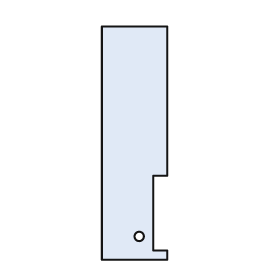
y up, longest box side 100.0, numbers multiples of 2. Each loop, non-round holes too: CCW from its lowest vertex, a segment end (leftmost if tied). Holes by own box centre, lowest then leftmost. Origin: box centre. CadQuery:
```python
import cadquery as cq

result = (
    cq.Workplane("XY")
    .moveTo(-14.0, -50.0)
    .lineTo(14.0, -50.0)
    .lineTo(14.0, -46.0)
    .lineTo(8.0, -46.0)
    .lineTo(8.0, -14.0)
    .lineTo(14.0, -14.0)
    .lineTo(14.0, 50.0)
    .lineTo(-14.0, 50.0)
    .close()
    .moveTo(2.0, -40.0)
    .circle(2.0)
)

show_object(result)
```